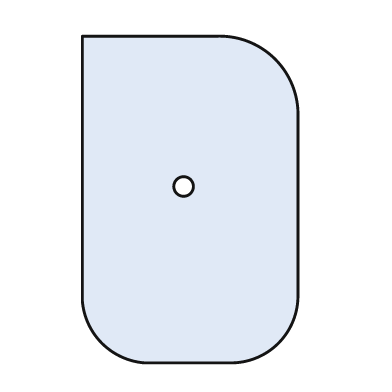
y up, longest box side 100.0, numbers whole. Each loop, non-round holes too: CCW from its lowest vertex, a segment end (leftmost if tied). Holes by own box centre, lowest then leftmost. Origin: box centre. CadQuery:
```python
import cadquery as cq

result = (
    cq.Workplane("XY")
    .moveTo(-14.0, -50.0)
    .lineTo(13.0, -50.0)
    .threePointArc((27.0, -44.0), (33.0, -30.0))
    .lineTo(33.0, 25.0)
    .threePointArc((26.0, 43.0), (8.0, 50.0))
    .lineTo(-33.0, 50.0)
    .lineTo(-33.0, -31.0)
    .threePointArc((-27.0, -44.0), (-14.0, -50.0))
    .close()
    .moveTo(-2.0, 4.0)
    .circle(3.0)
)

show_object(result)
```